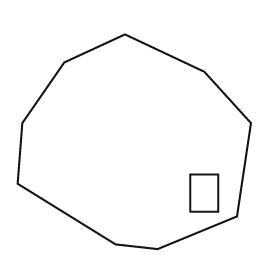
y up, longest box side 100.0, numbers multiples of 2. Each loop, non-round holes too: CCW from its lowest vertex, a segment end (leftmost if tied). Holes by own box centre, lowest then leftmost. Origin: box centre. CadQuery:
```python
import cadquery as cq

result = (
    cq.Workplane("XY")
    .moveTo(10.0, -46.0)
    .lineTo(44.0, -32.0)
    .lineTo(50.0, 8.0)
    .lineTo(30.0, 30.0)
    .lineTo(-4.0, 46.0)
    .lineTo(-30.0, 34.0)
    .lineTo(-48.0, 8.0)
    .lineTo(-50.0, -18.0)
    .lineTo(-8.0, -44.0)
    .close()
    .moveTo(24.0, -30.0)
    .lineTo(36.0, -30.0)
    .lineTo(36.0, -14.0)
    .lineTo(24.0, -14.0)
    .close()
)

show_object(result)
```